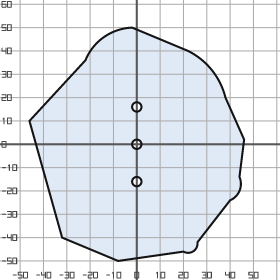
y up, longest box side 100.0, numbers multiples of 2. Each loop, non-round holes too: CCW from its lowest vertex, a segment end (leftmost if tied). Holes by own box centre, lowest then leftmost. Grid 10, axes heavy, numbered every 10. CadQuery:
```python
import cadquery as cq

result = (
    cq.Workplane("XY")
    .moveTo(-8.0, -50.0)
    .lineTo(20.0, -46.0)
    .threePointArc((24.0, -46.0), (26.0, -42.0))
    .lineTo(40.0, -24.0)
    .threePointArc((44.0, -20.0), (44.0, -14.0))
    .lineTo(46.0, 2.0)
    .lineTo(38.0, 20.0)
    .threePointArc((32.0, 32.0), (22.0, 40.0))
    .lineTo(-2.0, 50.0)
    .threePointArc((-14.0, 46.0), (-22.0, 36.0))
    .lineTo(-46.0, 10.0)
    .lineTo(-32.0, -40.0)
    .close()
    .moveTo(0.0, -16.0)
    .circle(2.0)
    .moveTo(0.0, 0.0)
    .circle(2.0)
    .moveTo(0.0, 16.0)
    .circle(2.0)
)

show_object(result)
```